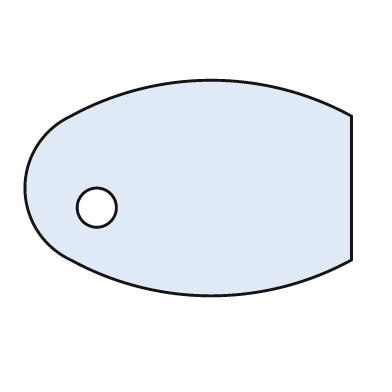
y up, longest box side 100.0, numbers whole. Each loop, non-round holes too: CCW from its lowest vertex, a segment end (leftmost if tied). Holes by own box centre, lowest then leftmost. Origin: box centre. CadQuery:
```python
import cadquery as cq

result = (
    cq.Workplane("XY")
    .moveTo(-36.0, -22.0)
    .threePointArc((7.0, -33.0), (50.0, -22.0))
    .lineTo(50.0, 22.0)
    .threePointArc((7.0, 33.0), (-36.0, 22.0))
    .threePointArc((-50.0, 0.0), (-36.0, -22.0))
    .close()
    .moveTo(-28.0, -6.0)
    .circle(6.0)
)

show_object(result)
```